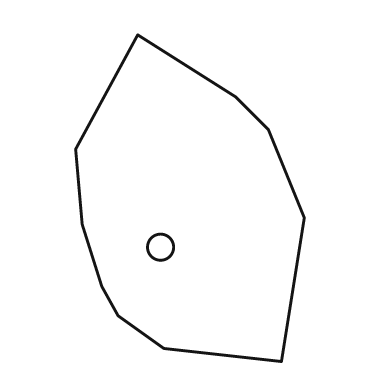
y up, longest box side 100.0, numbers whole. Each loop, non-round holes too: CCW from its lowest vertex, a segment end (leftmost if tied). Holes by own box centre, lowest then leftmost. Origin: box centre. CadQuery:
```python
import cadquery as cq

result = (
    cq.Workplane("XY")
    .moveTo(28.0, -50.0)
    .lineTo(35.0, -6.0)
    .lineTo(24.0, 21.0)
    .lineTo(14.0, 31.0)
    .lineTo(-16.0, 50.0)
    .lineTo(-35.0, 15.0)
    .lineTo(-33.0, -8.0)
    .lineTo(-27.0, -27.0)
    .lineTo(-22.0, -36.0)
    .lineTo(-8.0, -46.0)
    .close()
    .moveTo(-9.0, -15.0)
    .circle(4.0)
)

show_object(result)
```